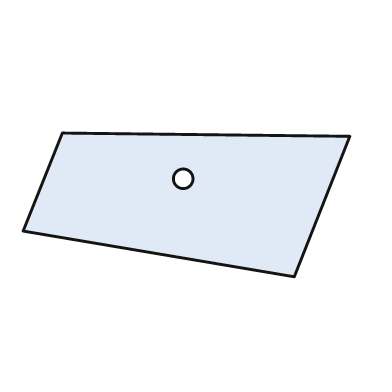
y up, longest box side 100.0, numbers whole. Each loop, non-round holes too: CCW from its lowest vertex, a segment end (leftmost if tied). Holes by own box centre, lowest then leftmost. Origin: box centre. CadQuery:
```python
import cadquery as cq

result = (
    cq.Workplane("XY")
    .moveTo(33.0, -22.0)
    .lineTo(50.0, 21.0)
    .lineTo(-38.0, 22.0)
    .lineTo(-50.0, -8.0)
    .close()
    .moveTo(-1.0, 8.0)
    .circle(3.0)
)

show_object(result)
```